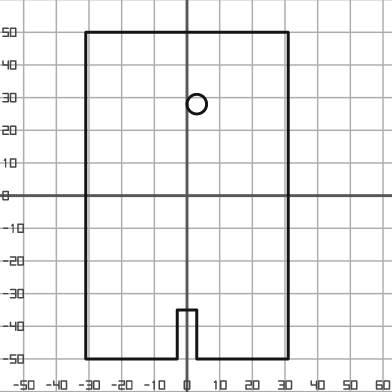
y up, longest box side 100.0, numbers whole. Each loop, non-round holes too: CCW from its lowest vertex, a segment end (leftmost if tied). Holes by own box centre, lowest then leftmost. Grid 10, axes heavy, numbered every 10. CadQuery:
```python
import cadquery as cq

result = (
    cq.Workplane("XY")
    .moveTo(-31.0, -50.0)
    .lineTo(-3.0, -50.0)
    .lineTo(-3.0, -35.0)
    .lineTo(3.0, -35.0)
    .lineTo(3.0, -50.0)
    .lineTo(31.0, -50.0)
    .lineTo(31.0, 50.0)
    .lineTo(-31.0, 50.0)
    .close()
    .moveTo(3.0, 28.0)
    .circle(3.0)
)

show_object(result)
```